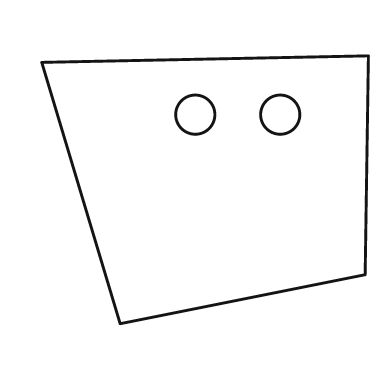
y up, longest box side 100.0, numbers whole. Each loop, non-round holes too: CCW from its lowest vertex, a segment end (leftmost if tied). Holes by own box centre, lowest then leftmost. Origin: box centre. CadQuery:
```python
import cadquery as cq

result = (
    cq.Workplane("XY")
    .moveTo(-26.0, -41.0)
    .lineTo(49.0, -26.0)
    .lineTo(50.0, 41.0)
    .lineTo(-50.0, 39.0)
    .close()
    .moveTo(-3.0, 23.0)
    .circle(6.0)
    .moveTo(23.0, 23.0)
    .circle(6.0)
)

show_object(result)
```